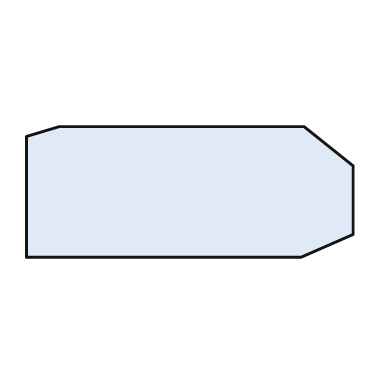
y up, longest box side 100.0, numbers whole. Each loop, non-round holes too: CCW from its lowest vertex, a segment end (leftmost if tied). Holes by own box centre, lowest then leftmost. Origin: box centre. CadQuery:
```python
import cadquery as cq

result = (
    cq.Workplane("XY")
    .moveTo(-50.0, -20.0)
    .lineTo(34.0, -20.0)
    .lineTo(50.0, -13.0)
    .lineTo(50.0, 8.0)
    .lineTo(35.0, 20.0)
    .lineTo(-40.0, 20.0)
    .lineTo(-50.0, 17.0)
    .close()
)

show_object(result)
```